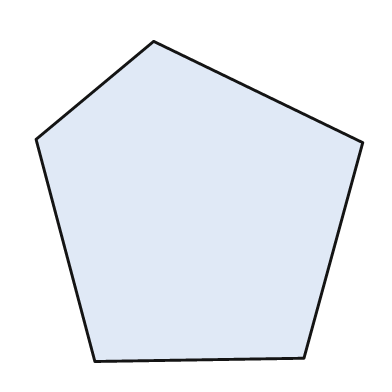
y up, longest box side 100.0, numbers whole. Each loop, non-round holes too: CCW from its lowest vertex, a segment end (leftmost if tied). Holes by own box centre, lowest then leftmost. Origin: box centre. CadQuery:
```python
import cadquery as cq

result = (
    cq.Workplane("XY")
    .moveTo(-32.0, -49.0)
    .lineTo(32.0, -48.0)
    .lineTo(50.0, 18.0)
    .lineTo(-14.0, 49.0)
    .lineTo(-50.0, 19.0)
    .close()
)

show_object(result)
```